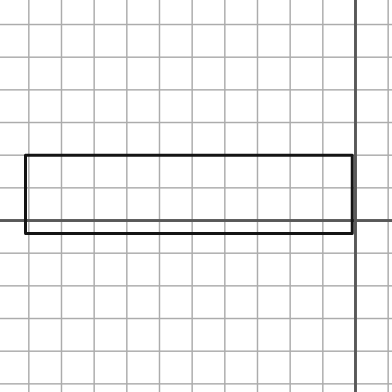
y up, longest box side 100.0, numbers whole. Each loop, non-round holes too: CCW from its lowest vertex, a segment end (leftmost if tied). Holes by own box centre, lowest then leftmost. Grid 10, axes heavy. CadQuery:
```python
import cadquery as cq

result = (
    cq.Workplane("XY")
    .moveTo(-101.0, -4.0)
    .lineTo(-1.0, -4.0)
    .lineTo(-1.0, 20.0)
    .lineTo(-101.0, 20.0)
    .close()
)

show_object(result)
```